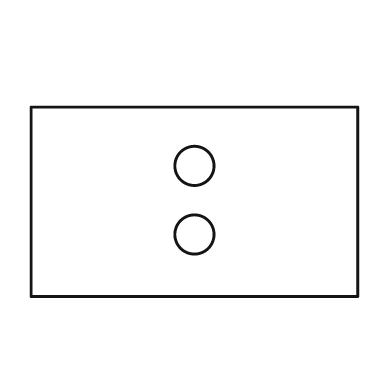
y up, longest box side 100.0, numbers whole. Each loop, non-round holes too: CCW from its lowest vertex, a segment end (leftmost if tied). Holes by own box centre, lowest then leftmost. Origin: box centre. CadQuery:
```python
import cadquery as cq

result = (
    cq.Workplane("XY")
    .moveTo(-50.0, -29.0)
    .lineTo(50.0, -29.0)
    .lineTo(50.0, 29.0)
    .lineTo(-50.0, 29.0)
    .close()
    .moveTo(0.0, -10.0)
    .circle(6.0)
    .moveTo(0.0, 11.0)
    .circle(6.0)
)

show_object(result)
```